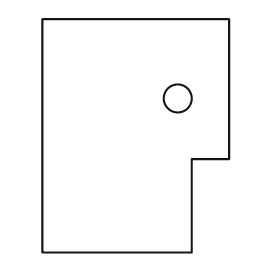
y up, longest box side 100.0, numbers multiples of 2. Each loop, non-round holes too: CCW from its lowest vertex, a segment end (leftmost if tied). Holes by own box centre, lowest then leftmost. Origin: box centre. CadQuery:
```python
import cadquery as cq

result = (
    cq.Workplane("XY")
    .moveTo(-40.0, -50.0)
    .lineTo(24.0, -50.0)
    .lineTo(24.0, -10.0)
    .lineTo(40.0, -10.0)
    .lineTo(40.0, 50.0)
    .lineTo(-40.0, 50.0)
    .close()
    .moveTo(18.0, 16.0)
    .circle(6.0)
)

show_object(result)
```